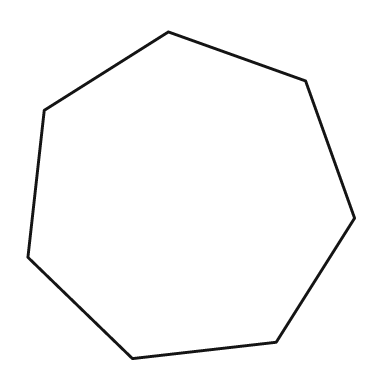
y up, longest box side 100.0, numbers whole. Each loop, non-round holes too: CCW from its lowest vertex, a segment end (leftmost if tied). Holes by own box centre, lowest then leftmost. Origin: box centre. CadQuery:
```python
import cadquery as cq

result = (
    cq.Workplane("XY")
    .moveTo(-18.0, -50.0)
    .lineTo(26.0, -45.0)
    .lineTo(50.0, -7.0)
    .lineTo(35.0, 35.0)
    .lineTo(-7.0, 50.0)
    .lineTo(-45.0, 26.0)
    .lineTo(-50.0, -19.0)
    .close()
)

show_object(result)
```